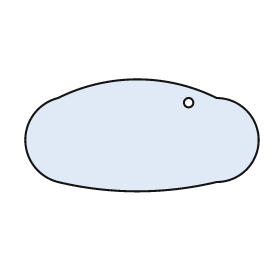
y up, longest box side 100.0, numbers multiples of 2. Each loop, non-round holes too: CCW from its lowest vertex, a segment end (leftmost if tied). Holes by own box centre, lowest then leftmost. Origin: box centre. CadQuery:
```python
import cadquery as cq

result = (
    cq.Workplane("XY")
    .moveTo(-36.0, -20.0)
    .threePointArc((-2.0, -24.0), (32.0, -20.0))
    .threePointArc((50.0, -2.0), (32.0, 16.0))
    .threePointArc((-2.0, 24.0), (-36.0, 16.0))
    .threePointArc((-50.0, -2.0), (-36.0, -20.0))
    .close()
    .moveTo(20.0, 14.0)
    .circle(2.0)
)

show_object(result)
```